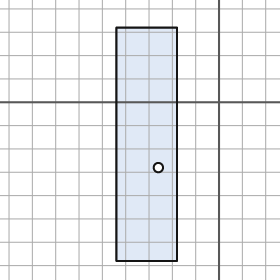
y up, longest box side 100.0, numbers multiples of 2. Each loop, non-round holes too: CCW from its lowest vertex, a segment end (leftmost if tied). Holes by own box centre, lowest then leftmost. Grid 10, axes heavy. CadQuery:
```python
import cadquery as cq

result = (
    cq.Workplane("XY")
    .moveTo(-44.0, -68.0)
    .lineTo(-18.0, -68.0)
    .lineTo(-18.0, 32.0)
    .lineTo(-44.0, 32.0)
    .close()
    .moveTo(-26.0, -28.0)
    .circle(2.0)
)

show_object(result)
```